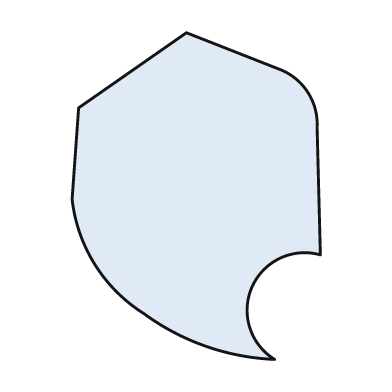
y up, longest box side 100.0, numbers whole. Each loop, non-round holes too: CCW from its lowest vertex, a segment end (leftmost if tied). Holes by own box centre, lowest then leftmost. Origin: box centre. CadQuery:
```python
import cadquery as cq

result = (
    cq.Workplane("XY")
    .moveTo(24.0, -50.0)
    .threePointArc((17.0, -28.0), (38.0, -18.0))
    .lineTo(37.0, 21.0)
    .threePointArc((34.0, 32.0), (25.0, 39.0))
    .lineTo(-3.0, 50.0)
    .lineTo(-36.0, 27.0)
    .lineTo(-38.0, -1.0)
    .threePointArc((-31.0, -21.0), (-16.0, -36.0))
    .threePointArc((3.0, -46.0), (24.0, -50.0))
    .close()
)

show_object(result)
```